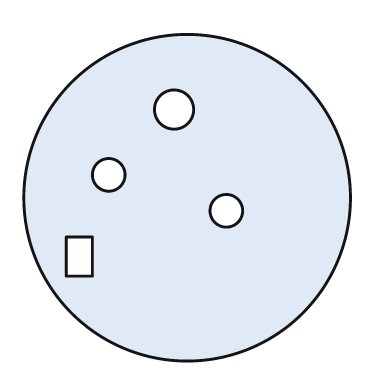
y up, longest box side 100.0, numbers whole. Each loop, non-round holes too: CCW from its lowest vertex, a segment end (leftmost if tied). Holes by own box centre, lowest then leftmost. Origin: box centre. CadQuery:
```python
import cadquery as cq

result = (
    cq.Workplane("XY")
    .moveTo(0.0, 0.0)
    .circle(50.0)
    .moveTo(-37.0, -24.0)
    .lineTo(-29.0, -24.0)
    .lineTo(-29.0, -12.0)
    .lineTo(-37.0, -12.0)
    .close()
    .moveTo(12.0, -4.0)
    .circle(5.0)
    .moveTo(-24.0, 7.0)
    .circle(5.0)
    .moveTo(-4.0, 27.0)
    .circle(6.0)
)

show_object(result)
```